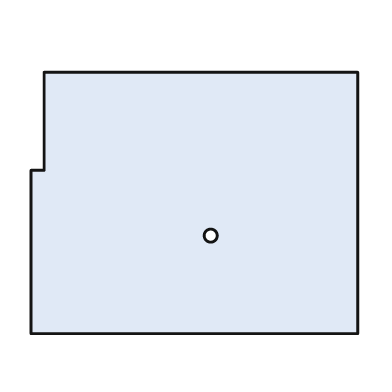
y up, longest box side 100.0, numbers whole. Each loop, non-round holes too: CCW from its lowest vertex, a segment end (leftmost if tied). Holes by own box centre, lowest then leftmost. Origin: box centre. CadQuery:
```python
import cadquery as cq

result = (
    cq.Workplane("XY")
    .moveTo(-50.0, -40.0)
    .lineTo(50.0, -40.0)
    .lineTo(50.0, 40.0)
    .lineTo(-46.0, 40.0)
    .lineTo(-46.0, 10.0)
    .lineTo(-50.0, 10.0)
    .close()
    .moveTo(5.0, -10.0)
    .circle(2.0)
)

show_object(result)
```